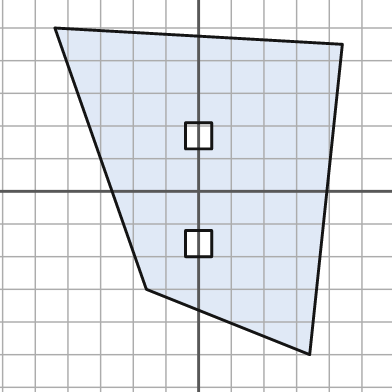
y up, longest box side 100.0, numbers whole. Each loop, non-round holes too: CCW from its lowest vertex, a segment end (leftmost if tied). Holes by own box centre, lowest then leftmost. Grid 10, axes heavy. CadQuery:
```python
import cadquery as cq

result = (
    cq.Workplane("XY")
    .moveTo(34.0, -50.0)
    .lineTo(44.0, 45.0)
    .lineTo(-44.0, 50.0)
    .lineTo(-16.0, -30.0)
    .close()
    .moveTo(-4.0, -20.0)
    .lineTo(4.0, -20.0)
    .lineTo(4.0, -12.0)
    .lineTo(-4.0, -12.0)
    .close()
    .moveTo(-4.0, 13.0)
    .lineTo(4.0, 13.0)
    .lineTo(4.0, 21.0)
    .lineTo(-4.0, 21.0)
    .close()
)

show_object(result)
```